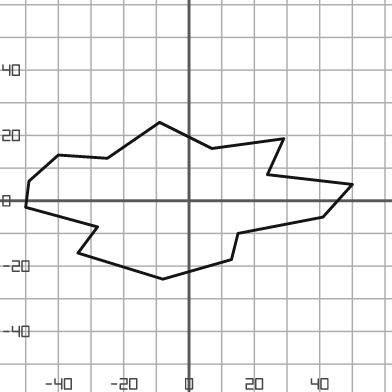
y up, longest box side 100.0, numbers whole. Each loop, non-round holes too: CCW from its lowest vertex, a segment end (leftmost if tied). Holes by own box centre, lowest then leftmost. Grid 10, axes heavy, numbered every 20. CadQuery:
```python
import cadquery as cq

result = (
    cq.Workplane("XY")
    .moveTo(-8.0, -24.0)
    .lineTo(13.0, -18.0)
    .lineTo(15.0, -10.0)
    .lineTo(41.0, -5.0)
    .lineTo(50.0, 5.0)
    .lineTo(24.0, 8.0)
    .lineTo(29.0, 19.0)
    .lineTo(7.0, 16.0)
    .lineTo(-9.0, 24.0)
    .lineTo(-25.0, 13.0)
    .lineTo(-40.0, 14.0)
    .lineTo(-49.0, 6.0)
    .lineTo(-50.0, -2.0)
    .lineTo(-28.0, -8.0)
    .lineTo(-34.0, -16.0)
    .close()
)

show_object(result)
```